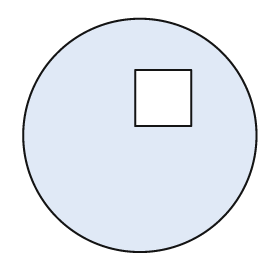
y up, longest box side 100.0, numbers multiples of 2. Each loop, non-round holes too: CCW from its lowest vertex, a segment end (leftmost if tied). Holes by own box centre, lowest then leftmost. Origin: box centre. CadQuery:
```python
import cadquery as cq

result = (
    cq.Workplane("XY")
    .moveTo(0.0, 0.0)
    .circle(50.0)
    .moveTo(-2.0, 4.0)
    .lineTo(22.0, 4.0)
    .lineTo(22.0, 28.0)
    .lineTo(-2.0, 28.0)
    .close()
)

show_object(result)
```